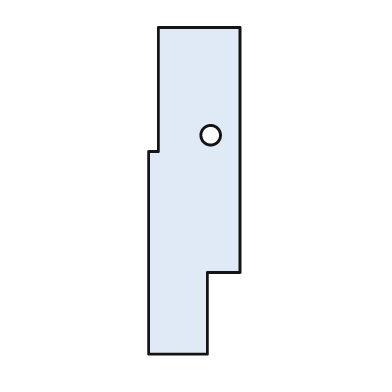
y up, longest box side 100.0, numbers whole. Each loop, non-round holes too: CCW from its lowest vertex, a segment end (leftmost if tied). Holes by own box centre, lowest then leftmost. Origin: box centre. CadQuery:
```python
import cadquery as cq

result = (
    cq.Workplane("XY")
    .moveTo(-14.0, -50.0)
    .lineTo(4.0, -50.0)
    .lineTo(4.0, -25.0)
    .lineTo(14.0, -25.0)
    .lineTo(14.0, 50.0)
    .lineTo(-11.0, 50.0)
    .lineTo(-11.0, 12.0)
    .lineTo(-14.0, 12.0)
    .close()
    .moveTo(5.0, 17.0)
    .circle(3.0)
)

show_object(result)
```